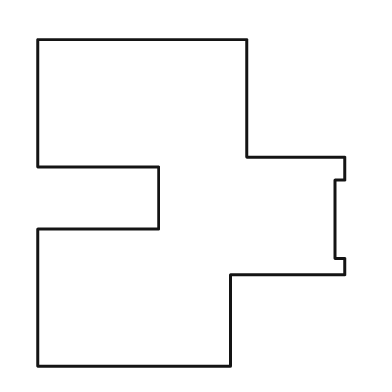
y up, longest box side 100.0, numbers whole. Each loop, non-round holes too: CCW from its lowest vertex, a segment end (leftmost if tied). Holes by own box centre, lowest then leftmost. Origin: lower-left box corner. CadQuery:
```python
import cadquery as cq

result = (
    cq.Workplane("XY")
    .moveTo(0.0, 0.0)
    .lineTo(59.0, 0.0)
    .lineTo(59.0, 28.0)
    .lineTo(94.0, 28.0)
    .lineTo(94.0, 33.0)
    .lineTo(91.0, 33.0)
    .lineTo(91.0, 57.0)
    .lineTo(94.0, 57.0)
    .lineTo(94.0, 64.0)
    .lineTo(64.0, 64.0)
    .lineTo(64.0, 100.0)
    .lineTo(0.0, 100.0)
    .lineTo(0.0, 61.0)
    .lineTo(37.0, 61.0)
    .lineTo(37.0, 42.0)
    .lineTo(0.0, 42.0)
    .close()
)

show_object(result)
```